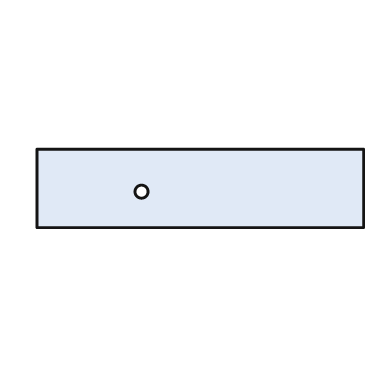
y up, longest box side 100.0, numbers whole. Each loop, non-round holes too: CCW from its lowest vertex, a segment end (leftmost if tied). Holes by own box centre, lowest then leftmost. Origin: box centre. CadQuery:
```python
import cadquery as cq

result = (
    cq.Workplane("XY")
    .moveTo(-50.0, -12.0)
    .lineTo(50.0, -12.0)
    .lineTo(50.0, 12.0)
    .lineTo(-50.0, 12.0)
    .close()
    .moveTo(-18.0, -1.0)
    .circle(2.0)
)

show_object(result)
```